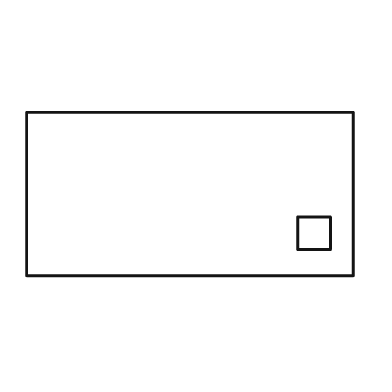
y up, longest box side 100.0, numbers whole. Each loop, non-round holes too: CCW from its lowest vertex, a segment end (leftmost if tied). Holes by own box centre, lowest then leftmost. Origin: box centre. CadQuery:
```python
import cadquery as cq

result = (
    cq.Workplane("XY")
    .moveTo(-50.0, -25.0)
    .lineTo(50.0, -25.0)
    .lineTo(50.0, 25.0)
    .lineTo(-50.0, 25.0)
    .close()
    .moveTo(33.0, -17.0)
    .lineTo(43.0, -17.0)
    .lineTo(43.0, -7.0)
    .lineTo(33.0, -7.0)
    .close()
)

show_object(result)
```